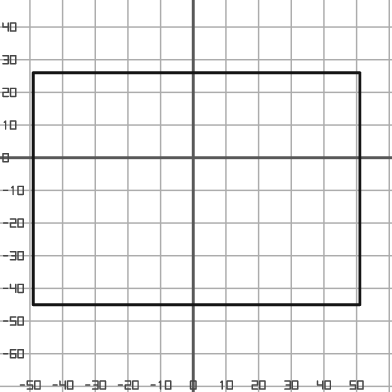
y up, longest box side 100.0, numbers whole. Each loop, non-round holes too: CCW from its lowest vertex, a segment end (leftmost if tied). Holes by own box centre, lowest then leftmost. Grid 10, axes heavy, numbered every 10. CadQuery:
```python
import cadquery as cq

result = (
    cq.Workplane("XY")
    .moveTo(-49.0, -45.0)
    .lineTo(51.0, -45.0)
    .lineTo(51.0, 26.0)
    .lineTo(-49.0, 26.0)
    .close()
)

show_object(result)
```